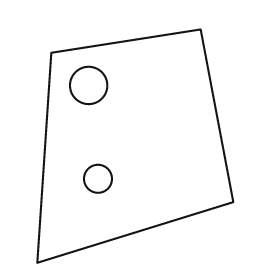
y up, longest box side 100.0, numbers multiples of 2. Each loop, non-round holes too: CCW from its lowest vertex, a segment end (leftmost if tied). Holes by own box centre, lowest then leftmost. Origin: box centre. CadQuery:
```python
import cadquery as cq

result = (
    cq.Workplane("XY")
    .moveTo(-42.0, -50.0)
    .lineTo(42.0, -24.0)
    .lineTo(28.0, 50.0)
    .lineTo(-36.0, 40.0)
    .close()
    .moveTo(-16.0, -14.0)
    .circle(6.0)
    .moveTo(-20.0, 26.0)
    .circle(8.0)
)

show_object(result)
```